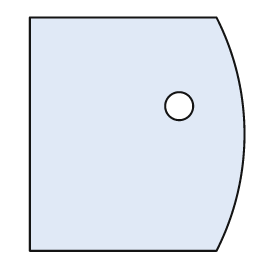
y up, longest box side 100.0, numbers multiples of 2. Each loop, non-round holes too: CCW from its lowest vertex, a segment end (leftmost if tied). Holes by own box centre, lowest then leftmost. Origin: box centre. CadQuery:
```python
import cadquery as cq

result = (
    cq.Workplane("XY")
    .moveTo(-46.0, -50.0)
    .lineTo(34.0, -50.0)
    .threePointArc((46.0, 0.0), (34.0, 50.0))
    .lineTo(-46.0, 50.0)
    .close()
    .moveTo(18.0, 12.0)
    .circle(6.0)
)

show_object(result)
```